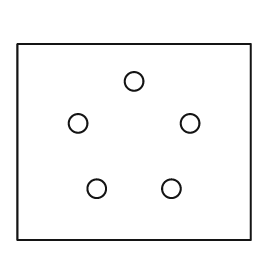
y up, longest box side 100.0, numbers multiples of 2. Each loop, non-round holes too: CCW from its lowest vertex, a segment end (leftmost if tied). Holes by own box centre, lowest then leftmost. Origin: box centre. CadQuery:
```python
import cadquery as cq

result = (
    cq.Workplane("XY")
    .moveTo(-50.0, -42.0)
    .lineTo(50.0, -42.0)
    .lineTo(50.0, 42.0)
    .lineTo(-50.0, 42.0)
    .close()
    .moveTo(-16.0, -20.0)
    .circle(4.0)
    .moveTo(16.0, -20.0)
    .circle(4.0)
    .moveTo(-24.0, 8.0)
    .circle(4.0)
    .moveTo(24.0, 8.0)
    .circle(4.0)
    .moveTo(0.0, 26.0)
    .circle(4.0)
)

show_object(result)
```